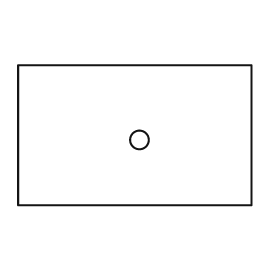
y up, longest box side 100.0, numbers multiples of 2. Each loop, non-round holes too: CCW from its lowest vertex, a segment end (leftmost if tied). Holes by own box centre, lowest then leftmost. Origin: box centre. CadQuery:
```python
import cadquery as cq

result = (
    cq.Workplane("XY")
    .moveTo(-50.0, -30.0)
    .lineTo(50.0, -30.0)
    .lineTo(50.0, 30.0)
    .lineTo(-50.0, 30.0)
    .close()
    .moveTo(2.0, -2.0)
    .circle(4.0)
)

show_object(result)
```